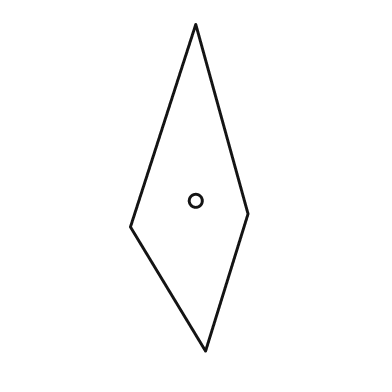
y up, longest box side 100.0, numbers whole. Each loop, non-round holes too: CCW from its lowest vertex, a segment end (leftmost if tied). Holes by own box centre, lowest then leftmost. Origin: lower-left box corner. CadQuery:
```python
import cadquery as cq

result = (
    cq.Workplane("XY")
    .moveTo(23.0, 0.0)
    .lineTo(36.0, 42.0)
    .lineTo(20.0, 100.0)
    .lineTo(0.0, 38.0)
    .close()
    .moveTo(20.0, 46.0)
    .circle(2.0)
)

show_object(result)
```